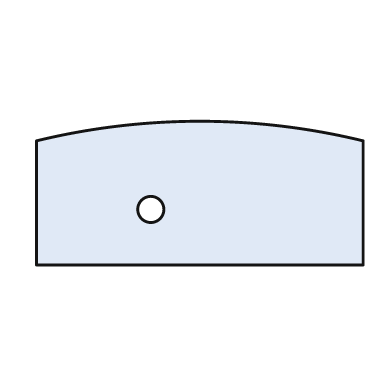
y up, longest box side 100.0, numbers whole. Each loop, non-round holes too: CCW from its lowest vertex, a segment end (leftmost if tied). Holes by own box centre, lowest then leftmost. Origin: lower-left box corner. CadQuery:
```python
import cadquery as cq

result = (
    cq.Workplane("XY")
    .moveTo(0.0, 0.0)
    .lineTo(100.0, 0.0)
    .lineTo(100.0, 38.0)
    .threePointArc((50.0, 44.0), (0.0, 38.0))
    .close()
    .moveTo(35.0, 17.0)
    .circle(4.0)
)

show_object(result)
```